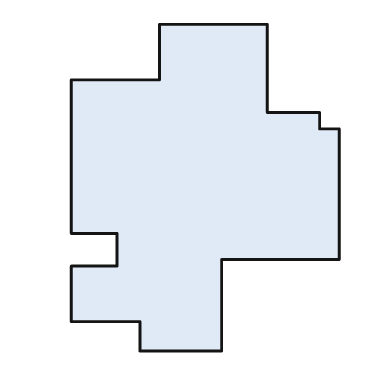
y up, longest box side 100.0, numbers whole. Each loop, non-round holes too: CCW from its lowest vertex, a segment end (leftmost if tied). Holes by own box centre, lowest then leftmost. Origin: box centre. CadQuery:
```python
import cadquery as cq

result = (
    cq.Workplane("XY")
    .moveTo(-20.0, -50.0)
    .lineTo(5.0, -50.0)
    .lineTo(5.0, -22.0)
    .lineTo(41.0, -22.0)
    .lineTo(41.0, 18.0)
    .lineTo(35.0, 18.0)
    .lineTo(35.0, 23.0)
    .lineTo(19.0, 23.0)
    .lineTo(19.0, 50.0)
    .lineTo(-14.0, 50.0)
    .lineTo(-14.0, 33.0)
    .lineTo(-41.0, 33.0)
    .lineTo(-41.0, -14.0)
    .lineTo(-27.0, -14.0)
    .lineTo(-27.0, -24.0)
    .lineTo(-41.0, -24.0)
    .lineTo(-41.0, -41.0)
    .lineTo(-20.0, -41.0)
    .close()
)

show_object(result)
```